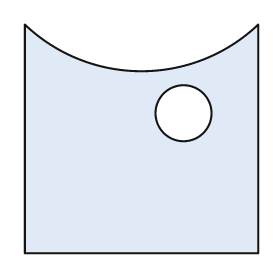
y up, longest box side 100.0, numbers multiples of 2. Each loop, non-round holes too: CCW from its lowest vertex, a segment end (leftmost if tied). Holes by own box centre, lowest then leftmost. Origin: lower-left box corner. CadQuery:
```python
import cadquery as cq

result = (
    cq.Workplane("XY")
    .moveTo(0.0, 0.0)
    .lineTo(100.0, 0.0)
    .lineTo(100.0, 98.0)
    .threePointArc((50.0, 78.0), (0.0, 98.0))
    .close()
    .moveTo(68.0, 60.0)
    .circle(12.0)
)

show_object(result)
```